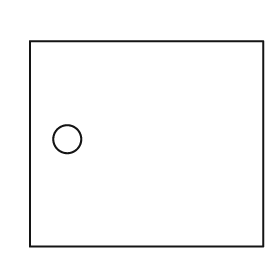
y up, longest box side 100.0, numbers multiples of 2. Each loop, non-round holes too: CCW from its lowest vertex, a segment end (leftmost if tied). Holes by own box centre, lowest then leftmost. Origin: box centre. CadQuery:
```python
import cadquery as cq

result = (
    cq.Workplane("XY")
    .moveTo(-50.0, -44.0)
    .lineTo(50.0, -44.0)
    .lineTo(50.0, 44.0)
    .lineTo(-50.0, 44.0)
    .close()
    .moveTo(-34.0, 2.0)
    .circle(6.0)
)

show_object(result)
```